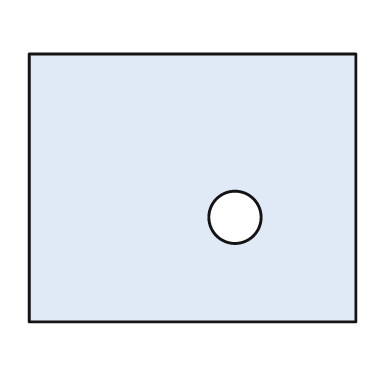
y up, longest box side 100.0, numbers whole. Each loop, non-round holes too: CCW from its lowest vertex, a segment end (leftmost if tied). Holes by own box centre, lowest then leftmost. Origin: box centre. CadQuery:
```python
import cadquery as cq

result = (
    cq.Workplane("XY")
    .moveTo(-50.0, -41.0)
    .lineTo(50.0, -41.0)
    .lineTo(50.0, 41.0)
    .lineTo(-50.0, 41.0)
    .close()
    .moveTo(13.0, -9.0)
    .circle(8.0)
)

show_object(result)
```